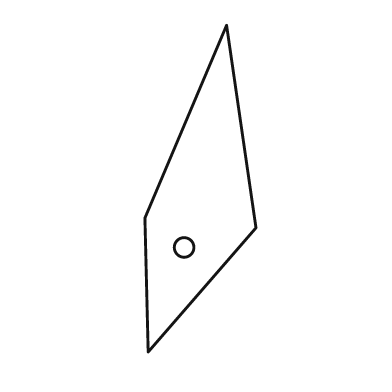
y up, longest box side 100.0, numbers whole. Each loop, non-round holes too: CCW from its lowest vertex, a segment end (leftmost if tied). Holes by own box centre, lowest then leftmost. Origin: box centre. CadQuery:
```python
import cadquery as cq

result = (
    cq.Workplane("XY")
    .moveTo(-16.0, -50.0)
    .lineTo(17.0, -12.0)
    .lineTo(8.0, 50.0)
    .lineTo(-17.0, -9.0)
    .close()
    .moveTo(-5.0, -18.0)
    .circle(3.0)
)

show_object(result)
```